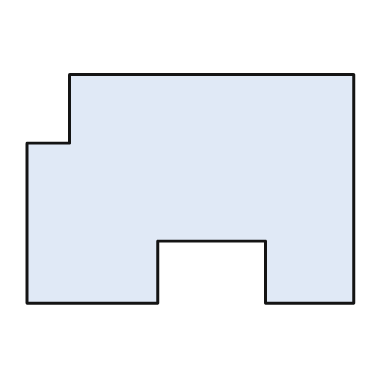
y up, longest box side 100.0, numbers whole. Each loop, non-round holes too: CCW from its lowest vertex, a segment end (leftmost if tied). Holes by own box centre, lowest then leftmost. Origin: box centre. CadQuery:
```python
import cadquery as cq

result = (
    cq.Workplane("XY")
    .moveTo(-50.0, -35.0)
    .lineTo(-10.0, -35.0)
    .lineTo(-10.0, -16.0)
    .lineTo(23.0, -16.0)
    .lineTo(23.0, -35.0)
    .lineTo(50.0, -35.0)
    .lineTo(50.0, 35.0)
    .lineTo(-37.0, 35.0)
    .lineTo(-37.0, 14.0)
    .lineTo(-50.0, 14.0)
    .close()
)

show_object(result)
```